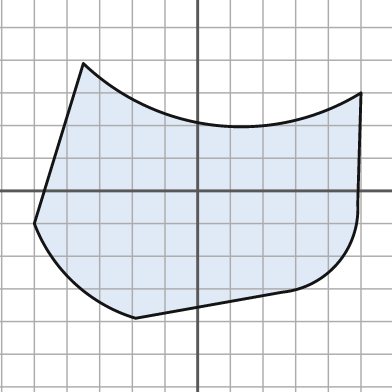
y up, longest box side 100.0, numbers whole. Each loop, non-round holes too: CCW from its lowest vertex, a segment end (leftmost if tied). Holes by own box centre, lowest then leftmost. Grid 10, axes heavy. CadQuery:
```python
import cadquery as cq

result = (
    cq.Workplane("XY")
    .moveTo(-19.0, -39.0)
    .lineTo(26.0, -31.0)
    .threePointArc((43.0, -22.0), (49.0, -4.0))
    .lineTo(50.0, 30.0)
    .threePointArc((6.0, 20.0), (-35.0, 39.0))
    .lineTo(-50.0, -10.0)
    .threePointArc((-38.0, -28.0), (-19.0, -39.0))
    .close()
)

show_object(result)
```